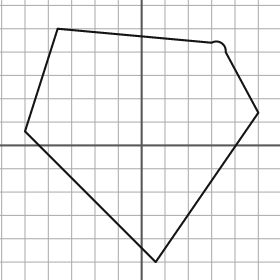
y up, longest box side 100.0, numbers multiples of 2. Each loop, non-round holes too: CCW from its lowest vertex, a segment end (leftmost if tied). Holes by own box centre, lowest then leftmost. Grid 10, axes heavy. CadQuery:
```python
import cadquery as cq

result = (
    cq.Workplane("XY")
    .moveTo(6.0, -50.0)
    .lineTo(50.0, 14.0)
    .lineTo(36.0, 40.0)
    .threePointArc((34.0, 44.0), (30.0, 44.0))
    .lineTo(-36.0, 50.0)
    .lineTo(-50.0, 6.0)
    .close()
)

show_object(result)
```